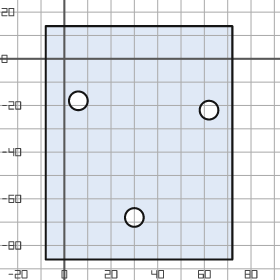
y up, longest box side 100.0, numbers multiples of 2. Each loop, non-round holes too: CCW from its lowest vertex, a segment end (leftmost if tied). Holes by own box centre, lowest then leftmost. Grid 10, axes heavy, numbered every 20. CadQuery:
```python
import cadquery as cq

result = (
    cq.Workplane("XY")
    .moveTo(-8.0, -86.0)
    .lineTo(72.0, -86.0)
    .lineTo(72.0, 14.0)
    .lineTo(-8.0, 14.0)
    .close()
    .moveTo(30.0, -68.0)
    .circle(4.0)
    .moveTo(62.0, -22.0)
    .circle(4.0)
    .moveTo(6.0, -18.0)
    .circle(4.0)
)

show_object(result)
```